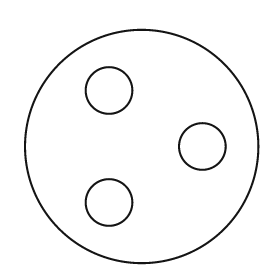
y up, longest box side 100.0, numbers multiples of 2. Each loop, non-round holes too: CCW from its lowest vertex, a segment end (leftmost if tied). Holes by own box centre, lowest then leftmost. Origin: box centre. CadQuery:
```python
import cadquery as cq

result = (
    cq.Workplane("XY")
    .moveTo(0.0, 0.0)
    .circle(50.0)
    .moveTo(-14.0, -24.0)
    .circle(10.0)
    .moveTo(26.0, 0.0)
    .circle(10.0)
    .moveTo(-14.0, 24.0)
    .circle(10.0)
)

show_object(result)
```